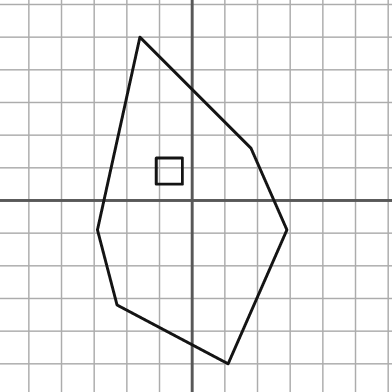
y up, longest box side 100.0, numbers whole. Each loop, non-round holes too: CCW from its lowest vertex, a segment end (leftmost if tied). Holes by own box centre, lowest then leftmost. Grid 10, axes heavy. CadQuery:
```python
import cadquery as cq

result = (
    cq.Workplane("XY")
    .moveTo(11.0, -50.0)
    .lineTo(29.0, -9.0)
    .lineTo(18.0, 16.0)
    .lineTo(-16.0, 50.0)
    .lineTo(-29.0, -9.0)
    .lineTo(-23.0, -32.0)
    .close()
    .moveTo(-11.0, 5.0)
    .lineTo(-3.0, 5.0)
    .lineTo(-3.0, 13.0)
    .lineTo(-11.0, 13.0)
    .close()
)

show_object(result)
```